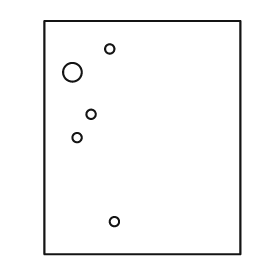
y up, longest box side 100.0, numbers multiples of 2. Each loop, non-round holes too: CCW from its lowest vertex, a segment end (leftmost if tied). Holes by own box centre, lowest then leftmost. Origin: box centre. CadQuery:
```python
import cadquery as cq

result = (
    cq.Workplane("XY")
    .moveTo(-42.0, -50.0)
    .lineTo(42.0, -50.0)
    .lineTo(42.0, 50.0)
    .lineTo(-42.0, 50.0)
    .close()
    .moveTo(-12.0, -36.0)
    .circle(2.0)
    .moveTo(-28.0, 0.0)
    .circle(2.0)
    .moveTo(-22.0, 10.0)
    .circle(2.0)
    .moveTo(-30.0, 28.0)
    .circle(4.0)
    .moveTo(-14.0, 38.0)
    .circle(2.0)
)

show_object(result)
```